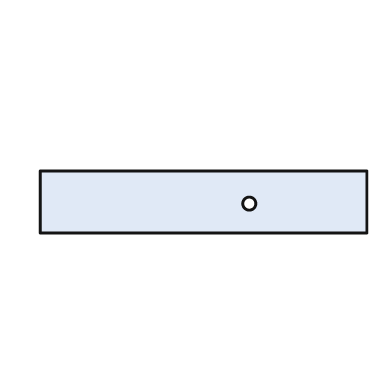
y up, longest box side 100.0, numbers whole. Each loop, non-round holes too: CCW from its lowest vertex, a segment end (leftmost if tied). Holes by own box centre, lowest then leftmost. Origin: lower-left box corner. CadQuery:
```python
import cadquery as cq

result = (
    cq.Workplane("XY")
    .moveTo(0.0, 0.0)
    .lineTo(100.0, 0.0)
    .lineTo(100.0, 19.0)
    .lineTo(0.0, 19.0)
    .close()
    .moveTo(64.0, 9.0)
    .circle(2.0)
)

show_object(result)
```